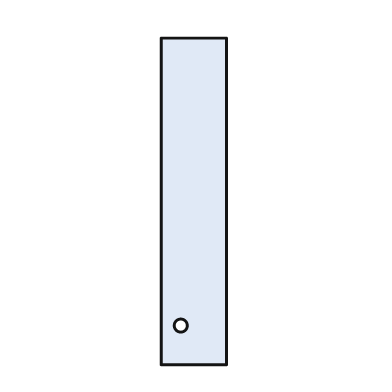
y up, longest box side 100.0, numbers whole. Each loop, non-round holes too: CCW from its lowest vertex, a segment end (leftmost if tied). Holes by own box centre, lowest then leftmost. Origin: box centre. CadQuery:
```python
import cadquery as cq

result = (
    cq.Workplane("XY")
    .moveTo(-10.0, -50.0)
    .lineTo(10.0, -50.0)
    .lineTo(10.0, 50.0)
    .lineTo(-10.0, 50.0)
    .close()
    .moveTo(-4.0, -38.0)
    .circle(2.0)
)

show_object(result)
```